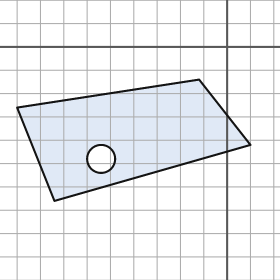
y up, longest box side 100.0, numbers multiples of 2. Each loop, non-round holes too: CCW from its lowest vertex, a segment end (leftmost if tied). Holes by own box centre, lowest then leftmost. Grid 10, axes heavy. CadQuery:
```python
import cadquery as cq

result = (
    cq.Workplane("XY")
    .moveTo(-74.0, -66.0)
    .lineTo(10.0, -42.0)
    .lineTo(-12.0, -14.0)
    .lineTo(-90.0, -26.0)
    .close()
    .moveTo(-54.0, -48.0)
    .circle(6.0)
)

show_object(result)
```